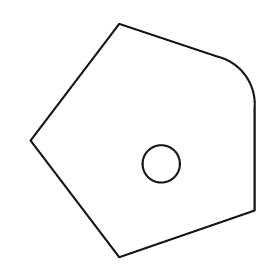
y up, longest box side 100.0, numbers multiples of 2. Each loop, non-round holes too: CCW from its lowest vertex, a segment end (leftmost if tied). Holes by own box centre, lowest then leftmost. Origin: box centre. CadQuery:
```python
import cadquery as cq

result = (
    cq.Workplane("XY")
    .moveTo(-10.0, -50.0)
    .lineTo(48.0, -30.0)
    .lineTo(48.0, 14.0)
    .threePointArc((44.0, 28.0), (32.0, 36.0))
    .lineTo(-10.0, 50.0)
    .lineTo(-48.0, 0.0)
    .close()
    .moveTo(8.0, -10.0)
    .circle(8.0)
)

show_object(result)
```